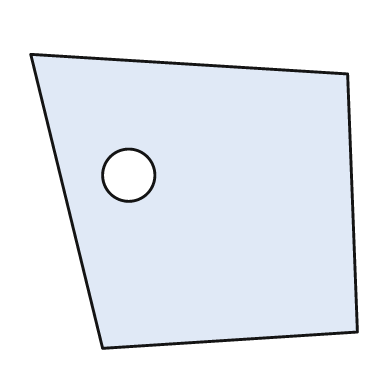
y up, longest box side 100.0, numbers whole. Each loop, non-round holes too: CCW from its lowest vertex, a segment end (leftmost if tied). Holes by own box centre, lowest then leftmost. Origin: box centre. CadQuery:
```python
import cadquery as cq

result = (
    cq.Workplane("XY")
    .moveTo(-28.0, -45.0)
    .lineTo(50.0, -40.0)
    .lineTo(47.0, 39.0)
    .lineTo(-50.0, 45.0)
    .close()
    .moveTo(-20.0, 8.0)
    .circle(8.0)
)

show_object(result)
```